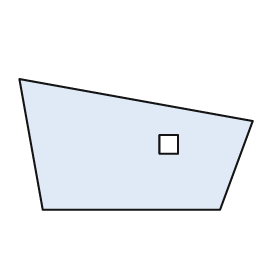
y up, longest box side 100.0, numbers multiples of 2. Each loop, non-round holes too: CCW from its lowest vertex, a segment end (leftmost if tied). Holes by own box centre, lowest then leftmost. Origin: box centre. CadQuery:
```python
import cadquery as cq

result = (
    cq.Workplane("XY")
    .moveTo(-40.0, -28.0)
    .lineTo(36.0, -28.0)
    .lineTo(50.0, 10.0)
    .lineTo(-50.0, 28.0)
    .close()
    .moveTo(10.0, -4.0)
    .lineTo(18.0, -4.0)
    .lineTo(18.0, 4.0)
    .lineTo(10.0, 4.0)
    .close()
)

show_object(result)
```